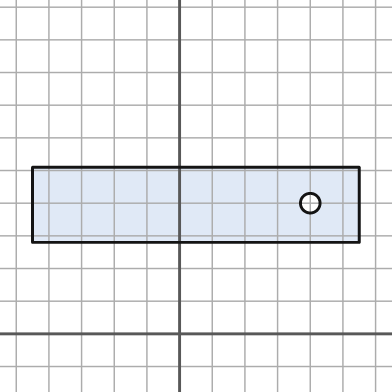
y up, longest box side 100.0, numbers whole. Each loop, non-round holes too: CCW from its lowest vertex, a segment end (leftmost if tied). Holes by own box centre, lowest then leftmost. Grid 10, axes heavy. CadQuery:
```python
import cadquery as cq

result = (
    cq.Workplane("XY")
    .moveTo(-45.0, 28.0)
    .lineTo(55.0, 28.0)
    .lineTo(55.0, 51.0)
    .lineTo(-45.0, 51.0)
    .close()
    .moveTo(40.0, 40.0)
    .circle(3.0)
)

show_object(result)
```